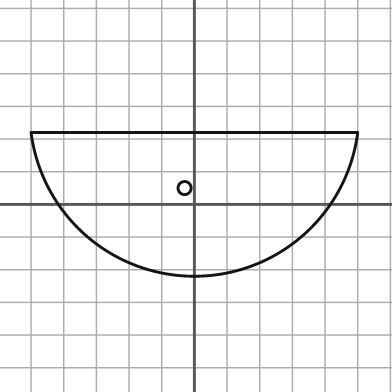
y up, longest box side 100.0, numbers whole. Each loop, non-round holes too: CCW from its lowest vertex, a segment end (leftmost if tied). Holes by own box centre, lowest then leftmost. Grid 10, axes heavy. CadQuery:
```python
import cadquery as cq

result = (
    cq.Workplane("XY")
    .moveTo(-50.0, 22.0)
    .threePointArc((0.0, -22.0), (50.0, 22.0))
    .close()
    .moveTo(-3.0, 5.0)
    .circle(2.0)
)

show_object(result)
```